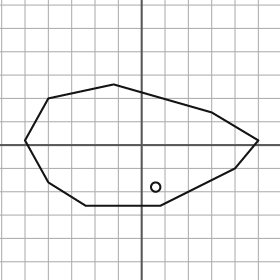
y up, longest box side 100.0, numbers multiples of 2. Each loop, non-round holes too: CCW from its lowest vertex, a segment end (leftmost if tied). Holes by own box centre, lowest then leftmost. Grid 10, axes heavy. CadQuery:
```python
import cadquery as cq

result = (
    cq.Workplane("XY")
    .moveTo(-24.0, -26.0)
    .lineTo(8.0, -26.0)
    .lineTo(40.0, -10.0)
    .lineTo(50.0, 2.0)
    .lineTo(30.0, 14.0)
    .lineTo(-12.0, 26.0)
    .lineTo(-40.0, 20.0)
    .lineTo(-50.0, 2.0)
    .lineTo(-40.0, -16.0)
    .close()
    .moveTo(6.0, -18.0)
    .circle(2.0)
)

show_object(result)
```